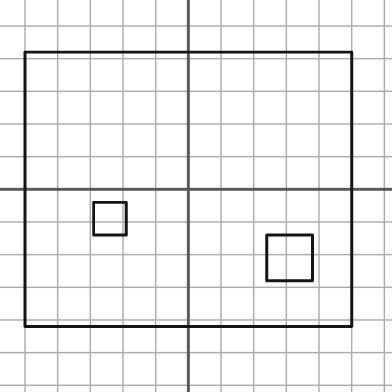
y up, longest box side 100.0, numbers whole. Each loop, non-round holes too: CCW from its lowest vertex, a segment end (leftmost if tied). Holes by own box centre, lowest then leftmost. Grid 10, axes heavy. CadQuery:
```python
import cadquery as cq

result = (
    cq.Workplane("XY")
    .moveTo(-50.0, -42.0)
    .lineTo(50.0, -42.0)
    .lineTo(50.0, 42.0)
    .lineTo(-50.0, 42.0)
    .close()
    .moveTo(24.0, -28.0)
    .lineTo(38.0, -28.0)
    .lineTo(38.0, -14.0)
    .lineTo(24.0, -14.0)
    .close()
    .moveTo(-29.0, -14.0)
    .lineTo(-19.0, -14.0)
    .lineTo(-19.0, -4.0)
    .lineTo(-29.0, -4.0)
    .close()
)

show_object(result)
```